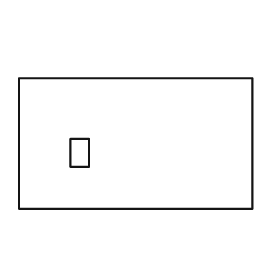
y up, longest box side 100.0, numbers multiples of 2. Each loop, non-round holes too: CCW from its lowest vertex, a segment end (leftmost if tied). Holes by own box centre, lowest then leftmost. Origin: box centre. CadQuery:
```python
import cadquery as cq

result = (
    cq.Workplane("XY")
    .moveTo(-50.0, -28.0)
    .lineTo(50.0, -28.0)
    .lineTo(50.0, 28.0)
    .lineTo(-50.0, 28.0)
    .close()
    .moveTo(-28.0, -10.0)
    .lineTo(-20.0, -10.0)
    .lineTo(-20.0, 2.0)
    .lineTo(-28.0, 2.0)
    .close()
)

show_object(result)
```